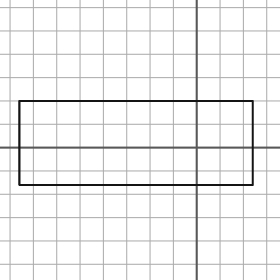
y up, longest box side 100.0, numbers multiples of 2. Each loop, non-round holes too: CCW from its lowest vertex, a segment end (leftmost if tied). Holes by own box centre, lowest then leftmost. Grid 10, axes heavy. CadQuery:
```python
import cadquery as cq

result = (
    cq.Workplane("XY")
    .moveTo(-76.0, -16.0)
    .lineTo(24.0, -16.0)
    .lineTo(24.0, 20.0)
    .lineTo(-76.0, 20.0)
    .close()
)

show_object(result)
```